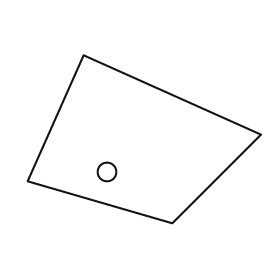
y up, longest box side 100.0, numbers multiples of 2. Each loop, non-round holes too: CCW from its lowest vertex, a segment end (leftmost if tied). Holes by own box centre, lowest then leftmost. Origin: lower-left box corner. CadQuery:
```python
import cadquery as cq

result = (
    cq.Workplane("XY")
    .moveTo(62.0, 0.0)
    .lineTo(100.0, 38.0)
    .lineTo(24.0, 72.0)
    .lineTo(0.0, 18.0)
    .close()
    .moveTo(34.0, 22.0)
    .circle(4.0)
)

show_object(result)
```